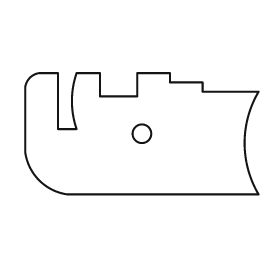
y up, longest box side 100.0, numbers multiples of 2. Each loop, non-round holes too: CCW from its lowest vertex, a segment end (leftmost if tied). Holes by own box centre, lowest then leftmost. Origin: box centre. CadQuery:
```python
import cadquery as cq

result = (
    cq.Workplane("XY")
    .moveTo(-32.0, -26.0)
    .lineTo(50.0, -26.0)
    .threePointArc((44.0, -4.0), (50.0, 18.0))
    .lineTo(26.0, 18.0)
    .lineTo(26.0, 22.0)
    .lineTo(12.0, 22.0)
    .lineTo(12.0, 26.0)
    .lineTo(-2.0, 26.0)
    .lineTo(-2.0, 16.0)
    .lineTo(-18.0, 16.0)
    .lineTo(-18.0, 26.0)
    .lineTo(-28.0, 26.0)
    .threePointArc((-30.0, 14.0), (-28.0, 2.0))
    .lineTo(-36.0, 2.0)
    .lineTo(-36.0, 26.0)
    .lineTo(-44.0, 26.0)
    .threePointArc((-48.0, 24.0), (-50.0, 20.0))
    .lineTo(-50.0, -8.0)
    .threePointArc((-44.0, -20.0), (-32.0, -26.0))
    .close()
    .moveTo(0.0, 0.0)
    .circle(4.0)
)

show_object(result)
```